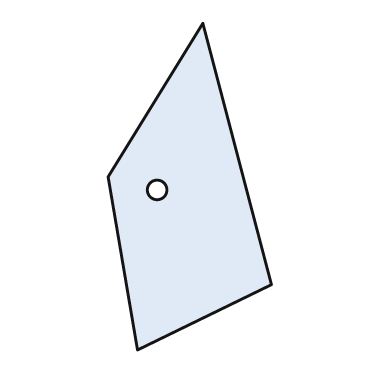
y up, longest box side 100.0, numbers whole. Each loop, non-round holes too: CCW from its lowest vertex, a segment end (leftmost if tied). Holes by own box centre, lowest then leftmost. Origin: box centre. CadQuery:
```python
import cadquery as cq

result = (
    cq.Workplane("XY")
    .moveTo(-16.0, -50.0)
    .lineTo(25.0, -30.0)
    .lineTo(4.0, 50.0)
    .lineTo(-25.0, 3.0)
    .close()
    .moveTo(-10.0, -1.0)
    .circle(3.0)
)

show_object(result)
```